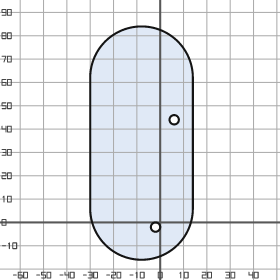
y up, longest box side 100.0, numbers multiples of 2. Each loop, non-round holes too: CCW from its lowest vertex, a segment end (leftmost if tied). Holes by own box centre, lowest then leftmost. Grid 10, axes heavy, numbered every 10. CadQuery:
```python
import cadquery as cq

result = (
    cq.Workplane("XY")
    .moveTo(-30.0, 6.0)
    .threePointArc((-8.0, -16.0), (14.0, 6.0))
    .lineTo(14.0, 62.0)
    .threePointArc((-8.0, 84.0), (-30.0, 62.0))
    .close()
    .moveTo(-2.0, -2.0)
    .circle(2.0)
    .moveTo(6.0, 44.0)
    .circle(2.0)
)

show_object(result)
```